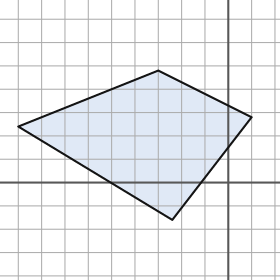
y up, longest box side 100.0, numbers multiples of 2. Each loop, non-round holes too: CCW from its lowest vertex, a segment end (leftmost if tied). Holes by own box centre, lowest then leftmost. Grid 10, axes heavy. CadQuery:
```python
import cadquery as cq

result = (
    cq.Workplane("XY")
    .moveTo(-24.0, -16.0)
    .lineTo(10.0, 28.0)
    .lineTo(-30.0, 48.0)
    .lineTo(-90.0, 24.0)
    .close()
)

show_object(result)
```